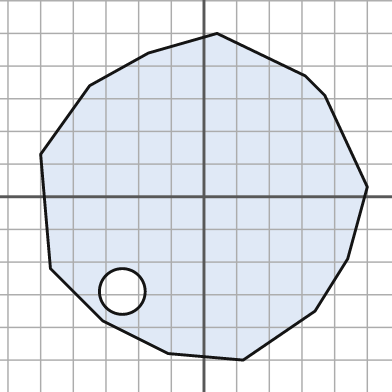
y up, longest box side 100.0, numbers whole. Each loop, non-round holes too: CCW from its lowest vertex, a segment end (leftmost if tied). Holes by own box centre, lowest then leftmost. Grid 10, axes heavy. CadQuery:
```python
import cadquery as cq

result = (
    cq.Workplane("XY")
    .moveTo(12.0, -50.0)
    .lineTo(34.0, -35.0)
    .lineTo(44.0, -19.0)
    .lineTo(50.0, 3.0)
    .lineTo(37.0, 31.0)
    .lineTo(31.0, 37.0)
    .lineTo(4.0, 50.0)
    .lineTo(-17.0, 44.0)
    .lineTo(-35.0, 34.0)
    .lineTo(-50.0, 13.0)
    .lineTo(-47.0, -22.0)
    .lineTo(-31.0, -38.0)
    .lineTo(-11.0, -48.0)
    .close()
    .moveTo(-25.0, -29.0)
    .circle(7.0)
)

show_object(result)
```